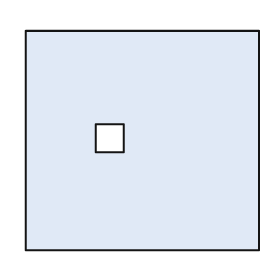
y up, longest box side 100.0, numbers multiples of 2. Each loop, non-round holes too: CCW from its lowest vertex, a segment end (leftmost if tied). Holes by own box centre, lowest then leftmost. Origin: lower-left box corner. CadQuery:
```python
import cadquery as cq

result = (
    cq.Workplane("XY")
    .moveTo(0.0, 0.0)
    .lineTo(100.0, 0.0)
    .lineTo(100.0, 94.0)
    .lineTo(0.0, 94.0)
    .close()
    .moveTo(30.0, 42.0)
    .lineTo(42.0, 42.0)
    .lineTo(42.0, 54.0)
    .lineTo(30.0, 54.0)
    .close()
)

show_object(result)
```